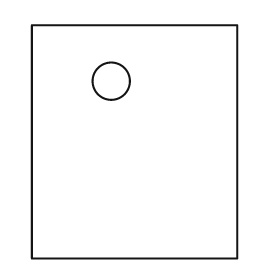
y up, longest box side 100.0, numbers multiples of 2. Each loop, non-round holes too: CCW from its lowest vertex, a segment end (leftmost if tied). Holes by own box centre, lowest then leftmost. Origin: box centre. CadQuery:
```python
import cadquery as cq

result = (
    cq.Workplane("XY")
    .moveTo(-44.0, -50.0)
    .lineTo(44.0, -50.0)
    .lineTo(44.0, 50.0)
    .lineTo(-44.0, 50.0)
    .close()
    .moveTo(-10.0, 26.0)
    .circle(8.0)
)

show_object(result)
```